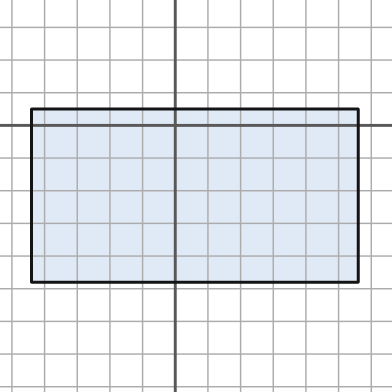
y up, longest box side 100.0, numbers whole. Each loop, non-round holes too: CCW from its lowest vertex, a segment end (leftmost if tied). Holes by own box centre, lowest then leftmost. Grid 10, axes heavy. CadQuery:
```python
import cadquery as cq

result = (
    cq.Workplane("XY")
    .moveTo(-44.0, -48.0)
    .lineTo(56.0, -48.0)
    .lineTo(56.0, 5.0)
    .lineTo(-44.0, 5.0)
    .close()
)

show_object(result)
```